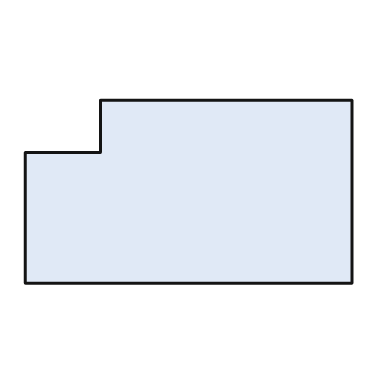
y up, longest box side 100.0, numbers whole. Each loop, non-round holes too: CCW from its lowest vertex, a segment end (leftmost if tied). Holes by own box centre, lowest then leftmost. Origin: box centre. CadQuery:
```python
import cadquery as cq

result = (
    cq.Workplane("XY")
    .moveTo(-50.0, -28.0)
    .lineTo(50.0, -28.0)
    .lineTo(50.0, 28.0)
    .lineTo(-27.0, 28.0)
    .lineTo(-27.0, 12.0)
    .lineTo(-50.0, 12.0)
    .close()
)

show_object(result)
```